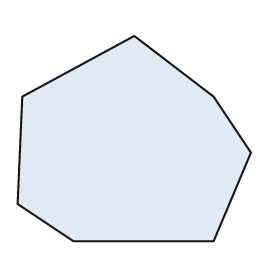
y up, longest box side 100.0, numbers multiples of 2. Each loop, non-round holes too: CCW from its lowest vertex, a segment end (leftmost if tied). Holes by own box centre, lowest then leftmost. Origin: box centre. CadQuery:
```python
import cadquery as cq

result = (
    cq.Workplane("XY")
    .moveTo(-26.0, -44.0)
    .lineTo(34.0, -44.0)
    .lineTo(50.0, -6.0)
    .lineTo(34.0, 18.0)
    .lineTo(0.0, 44.0)
    .lineTo(-48.0, 18.0)
    .lineTo(-50.0, -28.0)
    .close()
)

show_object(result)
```